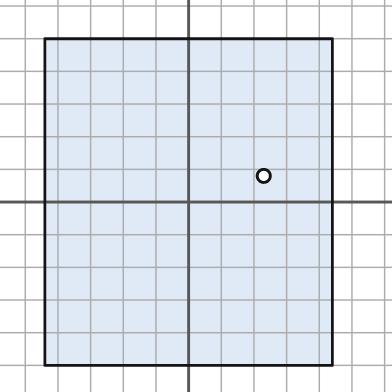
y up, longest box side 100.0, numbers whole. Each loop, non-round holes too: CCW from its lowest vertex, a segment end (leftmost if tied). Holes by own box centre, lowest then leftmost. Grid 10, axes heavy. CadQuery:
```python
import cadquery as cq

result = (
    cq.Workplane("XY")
    .moveTo(-44.0, -50.0)
    .lineTo(44.0, -50.0)
    .lineTo(44.0, 50.0)
    .lineTo(-44.0, 50.0)
    .close()
    .moveTo(23.0, 8.0)
    .circle(2.0)
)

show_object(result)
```